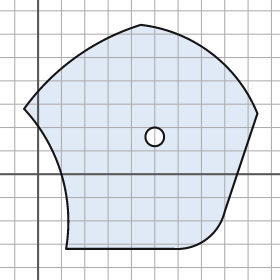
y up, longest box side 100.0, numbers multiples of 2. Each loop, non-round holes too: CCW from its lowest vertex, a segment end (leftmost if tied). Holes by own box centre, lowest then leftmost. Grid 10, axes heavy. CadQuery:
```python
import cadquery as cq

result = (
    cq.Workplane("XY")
    .moveTo(12.0, -32.0)
    .lineTo(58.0, -32.0)
    .threePointArc((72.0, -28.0), (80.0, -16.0))
    .lineTo(94.0, 26.0)
    .threePointArc((74.0, 52.0), (44.0, 64.0))
    .threePointArc((16.0, 50.0), (-6.0, 28.0))
    .threePointArc((10.0, 0.0), (12.0, -32.0))
    .close()
    .moveTo(50.0, 16.0)
    .circle(4.0)
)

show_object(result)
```